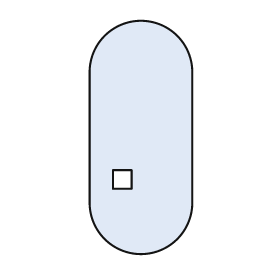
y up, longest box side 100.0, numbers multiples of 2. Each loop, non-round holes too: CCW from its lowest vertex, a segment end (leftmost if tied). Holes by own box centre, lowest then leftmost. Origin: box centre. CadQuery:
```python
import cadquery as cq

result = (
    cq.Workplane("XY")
    .moveTo(-22.0, -28.0)
    .threePointArc((0.0, -50.0), (22.0, -28.0))
    .lineTo(22.0, 28.0)
    .threePointArc((0.0, 50.0), (-22.0, 28.0))
    .close()
    .moveTo(-12.0, -22.0)
    .lineTo(-4.0, -22.0)
    .lineTo(-4.0, -14.0)
    .lineTo(-12.0, -14.0)
    .close()
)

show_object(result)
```